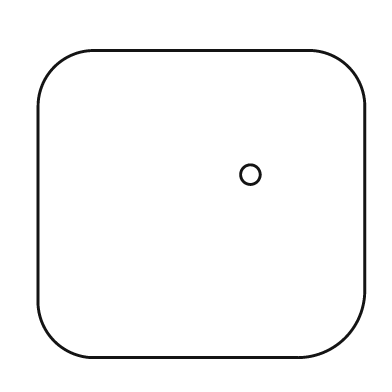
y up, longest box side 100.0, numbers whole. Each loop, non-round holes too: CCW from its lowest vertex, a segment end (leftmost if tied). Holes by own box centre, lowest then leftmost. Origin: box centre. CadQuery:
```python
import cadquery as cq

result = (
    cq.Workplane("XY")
    .moveTo(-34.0, -47.0)
    .lineTo(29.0, -47.0)
    .threePointArc((44.0, -41.0), (50.0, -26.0))
    .lineTo(50.0, 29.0)
    .threePointArc((45.0, 42.0), (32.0, 47.0))
    .lineTo(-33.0, 47.0)
    .threePointArc((-45.0, 42.0), (-50.0, 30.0))
    .lineTo(-50.0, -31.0)
    .threePointArc((-45.0, -42.0), (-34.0, -47.0))
    .close()
    .moveTo(15.0, 9.0)
    .circle(3.0)
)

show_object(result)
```